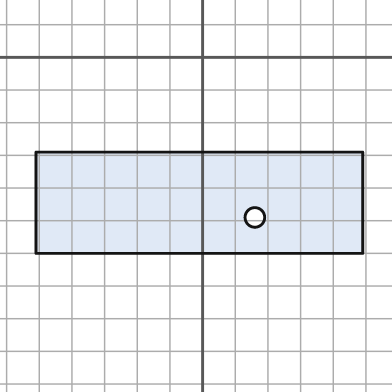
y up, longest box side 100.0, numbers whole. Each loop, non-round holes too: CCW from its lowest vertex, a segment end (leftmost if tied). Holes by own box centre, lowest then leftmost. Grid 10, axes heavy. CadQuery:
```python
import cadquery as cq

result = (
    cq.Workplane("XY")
    .moveTo(-51.0, -60.0)
    .lineTo(49.0, -60.0)
    .lineTo(49.0, -29.0)
    .lineTo(-51.0, -29.0)
    .close()
    .moveTo(16.0, -49.0)
    .circle(3.0)
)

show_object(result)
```